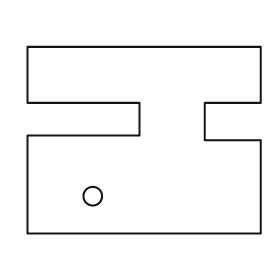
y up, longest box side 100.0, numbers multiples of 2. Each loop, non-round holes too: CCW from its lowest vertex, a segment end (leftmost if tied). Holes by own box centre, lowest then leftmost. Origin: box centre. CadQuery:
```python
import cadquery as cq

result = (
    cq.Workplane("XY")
    .moveTo(-50.0, -40.0)
    .lineTo(50.0, -40.0)
    .lineTo(50.0, 0.0)
    .lineTo(26.0, 0.0)
    .lineTo(26.0, 16.0)
    .lineTo(50.0, 16.0)
    .lineTo(50.0, 40.0)
    .lineTo(-50.0, 40.0)
    .lineTo(-50.0, 16.0)
    .lineTo(-2.0, 16.0)
    .lineTo(-2.0, 2.0)
    .lineTo(-50.0, 2.0)
    .close()
    .moveTo(-22.0, -24.0)
    .circle(4.0)
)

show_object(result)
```